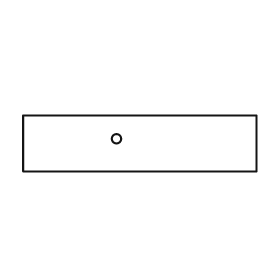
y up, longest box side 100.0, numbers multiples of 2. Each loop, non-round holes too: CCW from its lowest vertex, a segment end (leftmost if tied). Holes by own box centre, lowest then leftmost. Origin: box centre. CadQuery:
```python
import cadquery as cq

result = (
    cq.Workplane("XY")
    .moveTo(-50.0, -12.0)
    .lineTo(50.0, -12.0)
    .lineTo(50.0, 12.0)
    .lineTo(-50.0, 12.0)
    .close()
    .moveTo(-10.0, 2.0)
    .circle(2.0)
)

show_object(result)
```